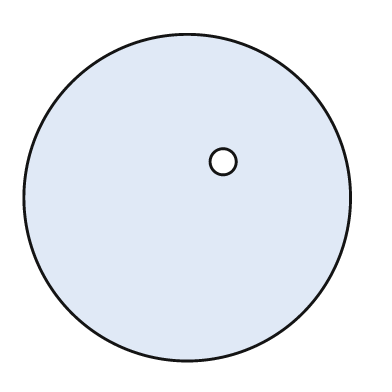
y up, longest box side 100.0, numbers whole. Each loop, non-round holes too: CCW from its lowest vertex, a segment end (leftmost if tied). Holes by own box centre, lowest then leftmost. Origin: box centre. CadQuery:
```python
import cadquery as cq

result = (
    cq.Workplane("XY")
    .moveTo(0.0, 0.0)
    .circle(50.0)
    .moveTo(11.0, 11.0)
    .circle(4.0)
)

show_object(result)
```